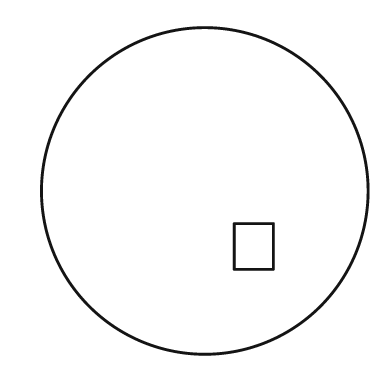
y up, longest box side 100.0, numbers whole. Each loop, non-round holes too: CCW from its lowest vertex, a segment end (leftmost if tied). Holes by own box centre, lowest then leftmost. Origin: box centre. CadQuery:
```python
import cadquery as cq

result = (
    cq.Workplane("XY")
    .moveTo(0.0, 0.0)
    .circle(50.0)
    .moveTo(9.0, -24.0)
    .lineTo(21.0, -24.0)
    .lineTo(21.0, -10.0)
    .lineTo(9.0, -10.0)
    .close()
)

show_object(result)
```